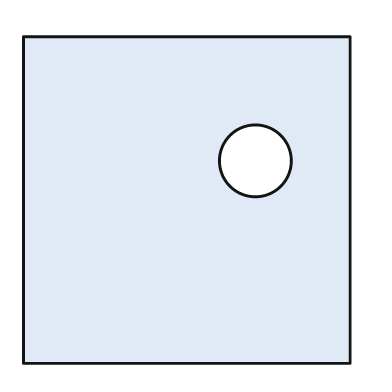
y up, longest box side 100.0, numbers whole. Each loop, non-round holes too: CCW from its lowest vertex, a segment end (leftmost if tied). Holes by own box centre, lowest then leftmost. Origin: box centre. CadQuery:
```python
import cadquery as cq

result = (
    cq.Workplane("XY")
    .moveTo(-50.0, -50.0)
    .lineTo(50.0, -50.0)
    .lineTo(50.0, 50.0)
    .lineTo(-50.0, 50.0)
    .close()
    .moveTo(21.0, 12.0)
    .circle(11.0)
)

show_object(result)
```